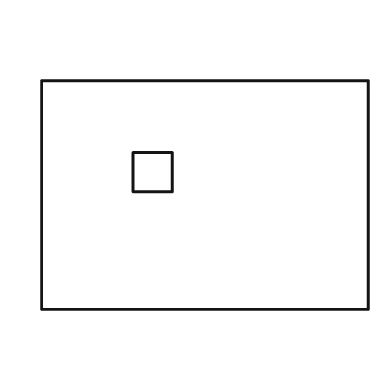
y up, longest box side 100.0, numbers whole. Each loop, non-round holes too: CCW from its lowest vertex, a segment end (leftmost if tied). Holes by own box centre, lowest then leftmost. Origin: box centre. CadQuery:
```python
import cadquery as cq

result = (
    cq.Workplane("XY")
    .moveTo(-50.0, -35.0)
    .lineTo(50.0, -35.0)
    .lineTo(50.0, 35.0)
    .lineTo(-50.0, 35.0)
    .close()
    .moveTo(-22.0, 1.0)
    .lineTo(-10.0, 1.0)
    .lineTo(-10.0, 13.0)
    .lineTo(-22.0, 13.0)
    .close()
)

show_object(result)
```